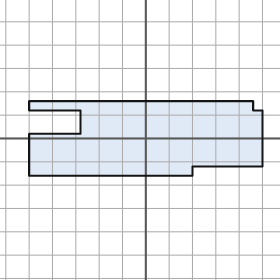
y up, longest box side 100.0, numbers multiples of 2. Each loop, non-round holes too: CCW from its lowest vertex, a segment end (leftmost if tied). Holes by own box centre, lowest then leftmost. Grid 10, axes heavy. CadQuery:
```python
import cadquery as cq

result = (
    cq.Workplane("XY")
    .moveTo(-50.0, -16.0)
    .lineTo(20.0, -16.0)
    .lineTo(20.0, -12.0)
    .lineTo(50.0, -12.0)
    .lineTo(50.0, 12.0)
    .lineTo(46.0, 12.0)
    .lineTo(46.0, 16.0)
    .lineTo(-50.0, 16.0)
    .lineTo(-50.0, 12.0)
    .lineTo(-28.0, 12.0)
    .lineTo(-28.0, 2.0)
    .lineTo(-50.0, 2.0)
    .close()
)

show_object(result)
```